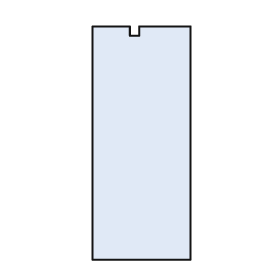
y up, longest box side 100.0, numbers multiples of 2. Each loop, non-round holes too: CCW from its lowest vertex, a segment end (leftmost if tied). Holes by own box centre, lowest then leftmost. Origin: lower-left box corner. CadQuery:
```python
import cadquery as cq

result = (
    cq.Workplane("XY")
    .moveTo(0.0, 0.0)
    .lineTo(42.0, 0.0)
    .lineTo(42.0, 100.0)
    .lineTo(20.0, 100.0)
    .lineTo(20.0, 96.0)
    .lineTo(16.0, 96.0)
    .lineTo(16.0, 100.0)
    .lineTo(0.0, 100.0)
    .close()
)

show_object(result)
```